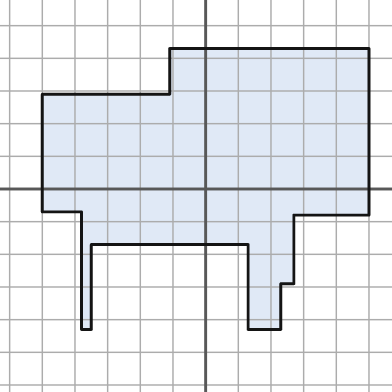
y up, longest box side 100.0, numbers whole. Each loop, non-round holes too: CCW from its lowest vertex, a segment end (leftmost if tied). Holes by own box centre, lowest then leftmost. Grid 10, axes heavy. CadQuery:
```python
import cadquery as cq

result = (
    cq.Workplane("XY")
    .moveTo(-38.0, -43.0)
    .lineTo(-35.0, -43.0)
    .lineTo(-35.0, -17.0)
    .lineTo(13.0, -17.0)
    .lineTo(13.0, -43.0)
    .lineTo(23.0, -43.0)
    .lineTo(23.0, -29.0)
    .lineTo(27.0, -29.0)
    .lineTo(27.0, -8.0)
    .lineTo(50.0, -8.0)
    .lineTo(50.0, 43.0)
    .lineTo(-11.0, 43.0)
    .lineTo(-11.0, 29.0)
    .lineTo(-50.0, 29.0)
    .lineTo(-50.0, -7.0)
    .lineTo(-38.0, -7.0)
    .close()
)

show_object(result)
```